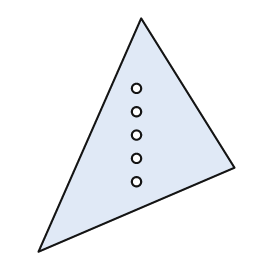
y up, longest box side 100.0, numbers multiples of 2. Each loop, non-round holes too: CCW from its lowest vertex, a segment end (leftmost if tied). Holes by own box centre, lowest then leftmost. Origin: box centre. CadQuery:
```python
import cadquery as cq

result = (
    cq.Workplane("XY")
    .moveTo(-42.0, -50.0)
    .lineTo(42.0, -14.0)
    .lineTo(2.0, 50.0)
    .close()
    .moveTo(0.0, -20.0)
    .circle(2.0)
    .moveTo(0.0, -10.0)
    .circle(2.0)
    .moveTo(0.0, 0.0)
    .circle(2.0)
    .moveTo(0.0, 10.0)
    .circle(2.0)
    .moveTo(0.0, 20.0)
    .circle(2.0)
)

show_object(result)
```